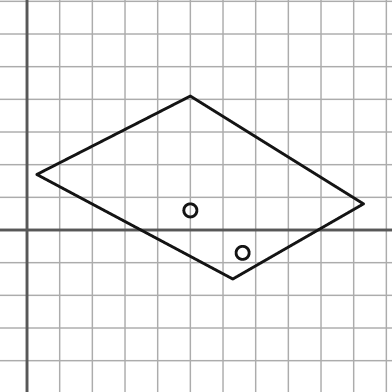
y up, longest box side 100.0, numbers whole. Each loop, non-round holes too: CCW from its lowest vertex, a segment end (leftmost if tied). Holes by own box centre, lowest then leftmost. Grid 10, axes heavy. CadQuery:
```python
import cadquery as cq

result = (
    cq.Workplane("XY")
    .moveTo(63.0, -15.0)
    .lineTo(103.0, 8.0)
    .lineTo(50.0, 41.0)
    .lineTo(3.0, 17.0)
    .close()
    .moveTo(66.0, -7.0)
    .circle(2.0)
    .moveTo(50.0, 6.0)
    .circle(2.0)
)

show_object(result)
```